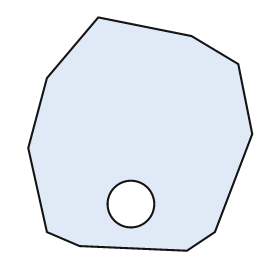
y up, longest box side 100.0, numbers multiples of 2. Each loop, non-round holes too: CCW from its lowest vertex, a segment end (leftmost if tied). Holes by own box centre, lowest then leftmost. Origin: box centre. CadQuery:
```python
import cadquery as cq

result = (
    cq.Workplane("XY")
    .moveTo(20.0, -50.0)
    .lineTo(32.0, -42.0)
    .lineTo(48.0, 0.0)
    .lineTo(42.0, 30.0)
    .lineTo(22.0, 42.0)
    .lineTo(-18.0, 50.0)
    .lineTo(-40.0, 24.0)
    .lineTo(-48.0, -6.0)
    .lineTo(-40.0, -42.0)
    .lineTo(-26.0, -48.0)
    .close()
    .moveTo(-4.0, -30.0)
    .circle(10.0)
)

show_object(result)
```